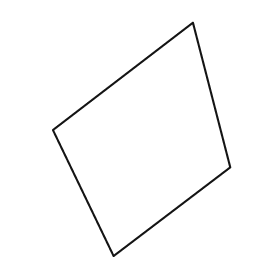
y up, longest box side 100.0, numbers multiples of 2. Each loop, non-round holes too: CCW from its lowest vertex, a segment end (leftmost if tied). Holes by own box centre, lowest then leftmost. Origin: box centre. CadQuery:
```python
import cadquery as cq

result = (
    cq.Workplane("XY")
    .moveTo(-12.0, -50.0)
    .lineTo(38.0, -12.0)
    .lineTo(22.0, 50.0)
    .lineTo(-38.0, 4.0)
    .close()
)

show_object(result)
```